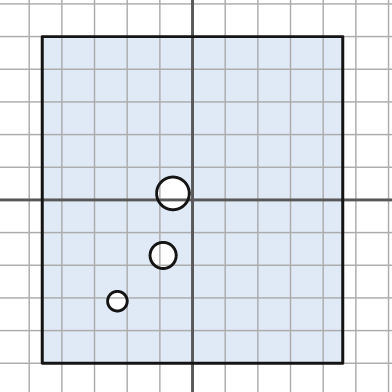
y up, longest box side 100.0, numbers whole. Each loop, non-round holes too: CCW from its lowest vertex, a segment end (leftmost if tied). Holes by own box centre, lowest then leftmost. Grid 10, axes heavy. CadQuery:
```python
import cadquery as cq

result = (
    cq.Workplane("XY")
    .moveTo(-46.0, -50.0)
    .lineTo(46.0, -50.0)
    .lineTo(46.0, 50.0)
    .lineTo(-46.0, 50.0)
    .close()
    .moveTo(-23.0, -31.0)
    .circle(3.0)
    .moveTo(-9.0, -17.0)
    .circle(4.0)
    .moveTo(-6.0, 2.0)
    .circle(5.0)
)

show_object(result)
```